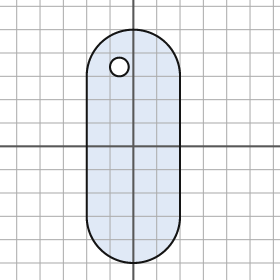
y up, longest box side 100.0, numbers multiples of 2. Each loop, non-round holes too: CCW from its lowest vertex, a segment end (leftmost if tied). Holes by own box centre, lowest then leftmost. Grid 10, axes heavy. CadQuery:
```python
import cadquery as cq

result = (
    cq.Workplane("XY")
    .moveTo(-20.0, -30.0)
    .threePointArc((0.0, -50.0), (20.0, -30.0))
    .lineTo(20.0, 30.0)
    .threePointArc((0.0, 50.0), (-20.0, 30.0))
    .close()
    .moveTo(-6.0, 34.0)
    .circle(4.0)
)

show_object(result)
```